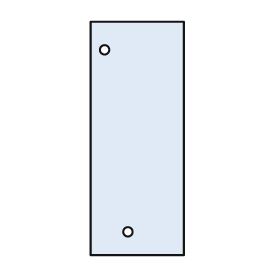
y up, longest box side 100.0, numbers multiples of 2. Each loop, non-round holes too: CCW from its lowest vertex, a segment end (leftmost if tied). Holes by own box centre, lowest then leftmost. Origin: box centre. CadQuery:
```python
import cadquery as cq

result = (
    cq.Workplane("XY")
    .moveTo(-20.0, -50.0)
    .lineTo(20.0, -50.0)
    .lineTo(20.0, 50.0)
    .lineTo(-20.0, 50.0)
    .close()
    .moveTo(-4.0, -40.0)
    .circle(2.0)
    .moveTo(-14.0, 38.0)
    .circle(2.0)
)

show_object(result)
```